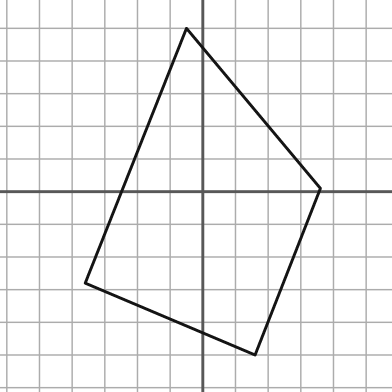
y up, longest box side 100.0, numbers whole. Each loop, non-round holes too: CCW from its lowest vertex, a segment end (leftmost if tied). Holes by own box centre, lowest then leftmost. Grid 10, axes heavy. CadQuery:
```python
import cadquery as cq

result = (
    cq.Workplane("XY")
    .moveTo(16.0, -50.0)
    .lineTo(36.0, 1.0)
    .lineTo(-5.0, 50.0)
    .lineTo(-36.0, -28.0)
    .close()
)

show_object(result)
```